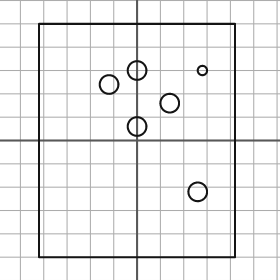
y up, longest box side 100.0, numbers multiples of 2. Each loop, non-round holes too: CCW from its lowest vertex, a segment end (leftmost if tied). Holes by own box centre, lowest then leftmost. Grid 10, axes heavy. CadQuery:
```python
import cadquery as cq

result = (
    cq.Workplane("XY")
    .moveTo(-42.0, -50.0)
    .lineTo(42.0, -50.0)
    .lineTo(42.0, 50.0)
    .lineTo(-42.0, 50.0)
    .close()
    .moveTo(26.0, -22.0)
    .circle(4.0)
    .moveTo(0.0, 6.0)
    .circle(4.0)
    .moveTo(14.0, 16.0)
    .circle(4.0)
    .moveTo(-12.0, 24.0)
    .circle(4.0)
    .moveTo(0.0, 30.0)
    .circle(4.0)
    .moveTo(28.0, 30.0)
    .circle(2.0)
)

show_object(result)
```